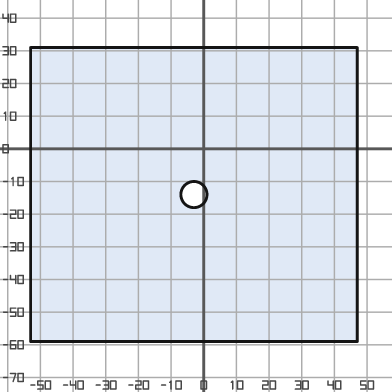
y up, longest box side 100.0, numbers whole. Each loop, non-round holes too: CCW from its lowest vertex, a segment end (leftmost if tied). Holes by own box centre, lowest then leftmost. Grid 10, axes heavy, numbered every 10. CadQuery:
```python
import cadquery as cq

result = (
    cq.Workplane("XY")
    .moveTo(-53.0, -59.0)
    .lineTo(47.0, -59.0)
    .lineTo(47.0, 31.0)
    .lineTo(-53.0, 31.0)
    .close()
    .moveTo(-3.0, -14.0)
    .circle(4.0)
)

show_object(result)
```